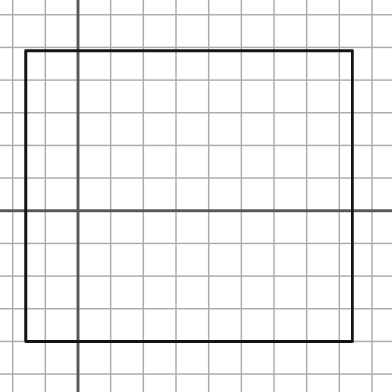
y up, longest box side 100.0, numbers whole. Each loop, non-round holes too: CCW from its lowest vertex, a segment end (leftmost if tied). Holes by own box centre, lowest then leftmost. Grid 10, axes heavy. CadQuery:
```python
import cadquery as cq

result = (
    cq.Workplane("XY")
    .moveTo(-16.0, -40.0)
    .lineTo(84.0, -40.0)
    .lineTo(84.0, 49.0)
    .lineTo(-16.0, 49.0)
    .close()
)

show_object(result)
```